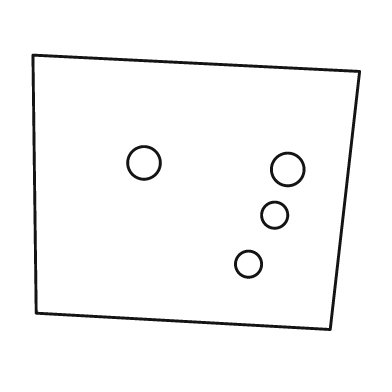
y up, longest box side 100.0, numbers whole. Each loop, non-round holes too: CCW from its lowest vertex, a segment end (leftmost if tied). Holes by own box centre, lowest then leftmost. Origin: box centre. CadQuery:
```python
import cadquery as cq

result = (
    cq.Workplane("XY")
    .moveTo(41.0, -42.0)
    .lineTo(50.0, 37.0)
    .lineTo(-50.0, 42.0)
    .lineTo(-49.0, -37.0)
    .close()
    .moveTo(16.0, -22.0)
    .circle(4.0)
    .moveTo(24.0, -7.0)
    .circle(4.0)
    .moveTo(28.0, 7.0)
    .circle(5.0)
    .moveTo(-16.0, 9.0)
    .circle(5.0)
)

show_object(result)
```